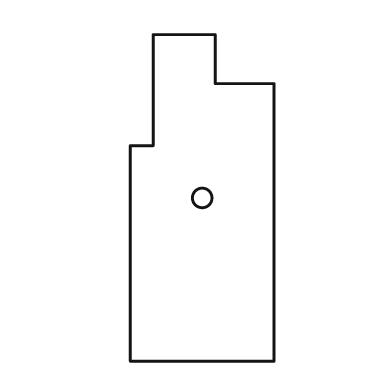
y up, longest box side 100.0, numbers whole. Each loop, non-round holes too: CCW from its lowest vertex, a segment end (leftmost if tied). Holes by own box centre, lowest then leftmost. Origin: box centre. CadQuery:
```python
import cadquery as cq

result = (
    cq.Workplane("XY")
    .moveTo(-22.0, -50.0)
    .lineTo(22.0, -50.0)
    .lineTo(22.0, 35.0)
    .lineTo(4.0, 35.0)
    .lineTo(4.0, 50.0)
    .lineTo(-15.0, 50.0)
    .lineTo(-15.0, 16.0)
    .lineTo(-22.0, 16.0)
    .close()
    .moveTo(0.0, 0.0)
    .circle(3.0)
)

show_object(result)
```